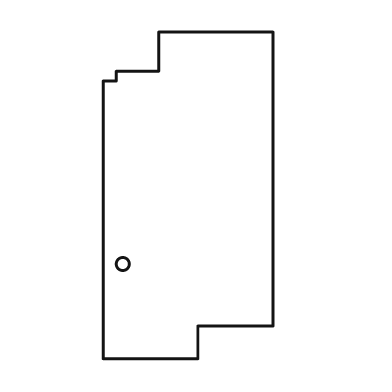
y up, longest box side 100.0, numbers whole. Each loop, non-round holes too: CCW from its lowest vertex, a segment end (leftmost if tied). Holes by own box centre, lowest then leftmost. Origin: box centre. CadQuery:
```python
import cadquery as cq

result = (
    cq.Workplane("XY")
    .moveTo(-26.0, -50.0)
    .lineTo(3.0, -50.0)
    .lineTo(3.0, -40.0)
    .lineTo(26.0, -40.0)
    .lineTo(26.0, 50.0)
    .lineTo(-9.0, 50.0)
    .lineTo(-9.0, 38.0)
    .lineTo(-22.0, 38.0)
    .lineTo(-22.0, 35.0)
    .lineTo(-26.0, 35.0)
    .close()
    .moveTo(-20.0, -21.0)
    .circle(2.0)
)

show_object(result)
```